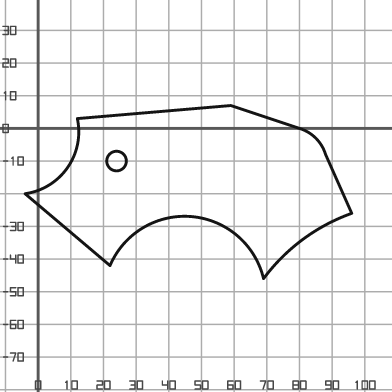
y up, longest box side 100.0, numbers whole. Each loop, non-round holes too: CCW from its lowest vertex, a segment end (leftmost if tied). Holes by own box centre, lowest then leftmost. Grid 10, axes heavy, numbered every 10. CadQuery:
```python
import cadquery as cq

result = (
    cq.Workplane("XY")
    .moveTo(69.0, -46.0)
    .threePointArc((81.0, -34.0), (96.0, -26.0))
    .lineTo(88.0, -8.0)
    .threePointArc((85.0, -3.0), (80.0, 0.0))
    .lineTo(59.0, 7.0)
    .lineTo(12.0, 3.0)
    .threePointArc((9.0, -12.0), (-4.0, -20.0))
    .lineTo(22.0, -42.0)
    .threePointArc((47.0, -27.0), (69.0, -46.0))
    .close()
    .moveTo(24.0, -10.0)
    .circle(3.0)
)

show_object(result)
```